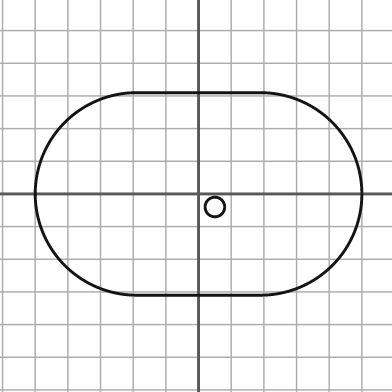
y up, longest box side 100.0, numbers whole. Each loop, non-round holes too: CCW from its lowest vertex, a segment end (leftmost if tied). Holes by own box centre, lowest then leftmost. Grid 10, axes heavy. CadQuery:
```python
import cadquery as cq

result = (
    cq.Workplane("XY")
    .moveTo(-19.0, -31.0)
    .lineTo(19.0, -31.0)
    .threePointArc((50.0, 0.0), (19.0, 31.0))
    .lineTo(-19.0, 31.0)
    .threePointArc((-50.0, 0.0), (-19.0, -31.0))
    .close()
    .moveTo(5.0, -4.0)
    .circle(3.0)
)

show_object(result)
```